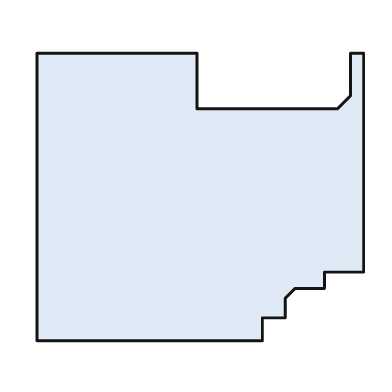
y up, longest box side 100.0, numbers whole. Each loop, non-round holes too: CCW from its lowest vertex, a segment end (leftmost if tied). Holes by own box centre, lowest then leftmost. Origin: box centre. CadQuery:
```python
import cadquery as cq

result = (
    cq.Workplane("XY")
    .moveTo(-50.0, -44.0)
    .lineTo(19.0, -44.0)
    .lineTo(19.0, -37.0)
    .lineTo(26.0, -37.0)
    .lineTo(26.0, -31.0)
    .lineTo(29.0, -28.0)
    .lineTo(38.0, -28.0)
    .lineTo(38.0, -23.0)
    .lineTo(50.0, -23.0)
    .lineTo(50.0, 44.0)
    .lineTo(46.0, 44.0)
    .lineTo(46.0, 31.0)
    .lineTo(42.0, 27.0)
    .lineTo(-1.0, 27.0)
    .lineTo(-1.0, 44.0)
    .lineTo(-50.0, 44.0)
    .close()
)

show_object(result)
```